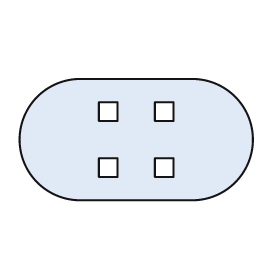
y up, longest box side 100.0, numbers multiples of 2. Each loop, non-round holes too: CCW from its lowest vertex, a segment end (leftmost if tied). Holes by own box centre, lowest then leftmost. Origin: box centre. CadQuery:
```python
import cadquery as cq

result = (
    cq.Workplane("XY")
    .moveTo(-24.0, -26.0)
    .lineTo(24.0, -26.0)
    .threePointArc((50.0, 0.0), (24.0, 26.0))
    .lineTo(-24.0, 26.0)
    .threePointArc((-50.0, 0.0), (-24.0, -26.0))
    .close()
    .moveTo(-16.0, -16.0)
    .lineTo(-8.0, -16.0)
    .lineTo(-8.0, -8.0)
    .lineTo(-16.0, -8.0)
    .close()
    .moveTo(8.0, -16.0)
    .lineTo(16.0, -16.0)
    .lineTo(16.0, -8.0)
    .lineTo(8.0, -8.0)
    .close()
    .moveTo(-16.0, 8.0)
    .lineTo(-8.0, 8.0)
    .lineTo(-8.0, 16.0)
    .lineTo(-16.0, 16.0)
    .close()
    .moveTo(8.0, 8.0)
    .lineTo(16.0, 8.0)
    .lineTo(16.0, 16.0)
    .lineTo(8.0, 16.0)
    .close()
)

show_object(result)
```